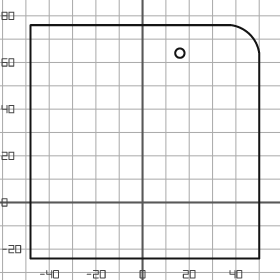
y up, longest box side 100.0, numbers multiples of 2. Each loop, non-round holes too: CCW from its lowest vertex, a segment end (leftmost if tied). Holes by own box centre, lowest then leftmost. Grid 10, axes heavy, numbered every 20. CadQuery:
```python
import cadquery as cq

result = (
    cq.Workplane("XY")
    .moveTo(-48.0, -24.0)
    .lineTo(50.0, -24.0)
    .lineTo(50.0, 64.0)
    .threePointArc((46.0, 72.0), (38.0, 76.0))
    .lineTo(-48.0, 76.0)
    .close()
    .moveTo(16.0, 64.0)
    .circle(2.0)
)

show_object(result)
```